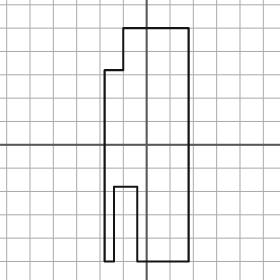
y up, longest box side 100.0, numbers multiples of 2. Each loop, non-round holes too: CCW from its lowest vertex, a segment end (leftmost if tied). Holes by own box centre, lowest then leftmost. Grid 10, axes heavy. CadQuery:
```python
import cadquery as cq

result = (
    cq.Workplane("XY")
    .moveTo(-18.0, -50.0)
    .lineTo(-14.0, -50.0)
    .lineTo(-14.0, -18.0)
    .lineTo(-4.0, -18.0)
    .lineTo(-4.0, -50.0)
    .lineTo(18.0, -50.0)
    .lineTo(18.0, 50.0)
    .lineTo(-10.0, 50.0)
    .lineTo(-10.0, 32.0)
    .lineTo(-18.0, 32.0)
    .close()
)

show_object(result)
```